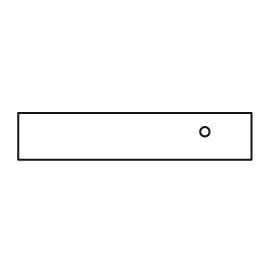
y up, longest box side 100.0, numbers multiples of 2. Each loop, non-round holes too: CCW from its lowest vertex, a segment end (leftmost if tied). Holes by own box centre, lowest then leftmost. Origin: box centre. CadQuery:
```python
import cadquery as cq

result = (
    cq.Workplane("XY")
    .moveTo(-50.0, -10.0)
    .lineTo(50.0, -10.0)
    .lineTo(50.0, 10.0)
    .lineTo(-50.0, 10.0)
    .close()
    .moveTo(30.0, 2.0)
    .circle(2.0)
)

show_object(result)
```